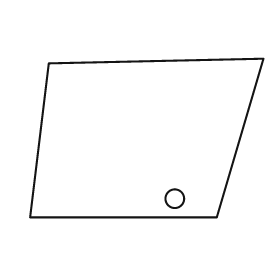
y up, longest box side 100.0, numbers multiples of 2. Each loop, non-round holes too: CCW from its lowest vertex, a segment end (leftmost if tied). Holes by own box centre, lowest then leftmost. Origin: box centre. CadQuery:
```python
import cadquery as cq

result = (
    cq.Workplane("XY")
    .moveTo(-50.0, -34.0)
    .lineTo(30.0, -34.0)
    .lineTo(50.0, 34.0)
    .lineTo(-42.0, 32.0)
    .close()
    .moveTo(12.0, -26.0)
    .circle(4.0)
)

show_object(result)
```